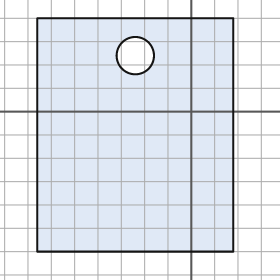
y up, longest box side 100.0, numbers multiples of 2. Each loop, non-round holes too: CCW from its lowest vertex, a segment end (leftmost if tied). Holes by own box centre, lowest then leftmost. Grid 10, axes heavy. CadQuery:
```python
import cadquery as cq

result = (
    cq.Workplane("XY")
    .moveTo(-66.0, -60.0)
    .lineTo(18.0, -60.0)
    .lineTo(18.0, 40.0)
    .lineTo(-66.0, 40.0)
    .close()
    .moveTo(-24.0, 24.0)
    .circle(8.0)
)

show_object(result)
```